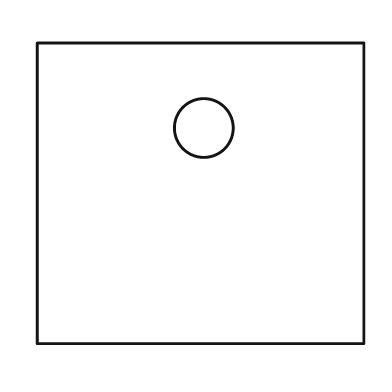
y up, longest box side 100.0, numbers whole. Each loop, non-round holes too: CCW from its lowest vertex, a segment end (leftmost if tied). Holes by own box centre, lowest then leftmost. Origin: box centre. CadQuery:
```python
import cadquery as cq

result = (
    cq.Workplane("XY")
    .moveTo(-50.0, -46.0)
    .lineTo(50.0, -46.0)
    .lineTo(50.0, 46.0)
    .lineTo(-50.0, 46.0)
    .close()
    .moveTo(1.0, 20.0)
    .circle(9.0)
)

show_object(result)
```